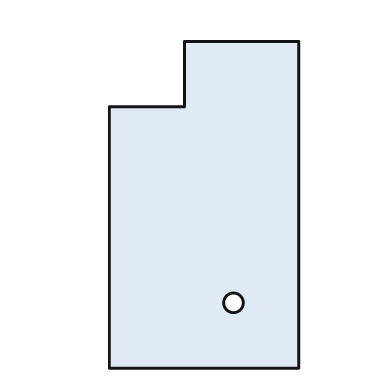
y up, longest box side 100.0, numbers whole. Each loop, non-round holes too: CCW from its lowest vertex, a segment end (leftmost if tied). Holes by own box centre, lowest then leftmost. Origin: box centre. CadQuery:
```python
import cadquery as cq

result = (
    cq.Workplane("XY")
    .moveTo(-29.0, -50.0)
    .lineTo(29.0, -50.0)
    .lineTo(29.0, 50.0)
    .lineTo(-6.0, 50.0)
    .lineTo(-6.0, 30.0)
    .lineTo(-29.0, 30.0)
    .close()
    .moveTo(9.0, -30.0)
    .circle(3.0)
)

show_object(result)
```